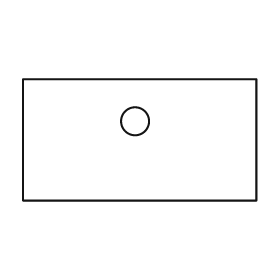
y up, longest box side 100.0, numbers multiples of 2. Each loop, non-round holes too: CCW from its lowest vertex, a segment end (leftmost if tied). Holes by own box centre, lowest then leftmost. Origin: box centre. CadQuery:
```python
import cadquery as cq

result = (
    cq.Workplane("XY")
    .moveTo(-50.0, -26.0)
    .lineTo(50.0, -26.0)
    .lineTo(50.0, 26.0)
    .lineTo(-50.0, 26.0)
    .close()
    .moveTo(-2.0, 8.0)
    .circle(6.0)
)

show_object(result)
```